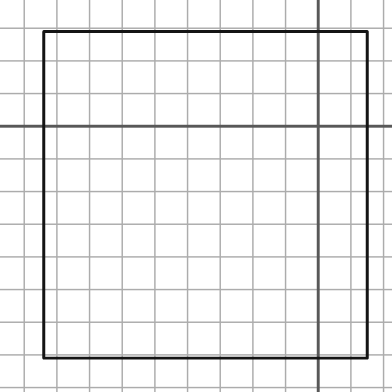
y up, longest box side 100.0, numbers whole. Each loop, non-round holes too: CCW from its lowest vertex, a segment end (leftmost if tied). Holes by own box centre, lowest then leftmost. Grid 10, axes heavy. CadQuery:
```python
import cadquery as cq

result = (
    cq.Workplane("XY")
    .moveTo(-84.0, -71.0)
    .lineTo(15.0, -71.0)
    .lineTo(15.0, 29.0)
    .lineTo(-84.0, 29.0)
    .close()
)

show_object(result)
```